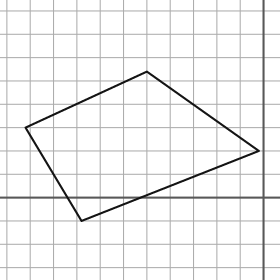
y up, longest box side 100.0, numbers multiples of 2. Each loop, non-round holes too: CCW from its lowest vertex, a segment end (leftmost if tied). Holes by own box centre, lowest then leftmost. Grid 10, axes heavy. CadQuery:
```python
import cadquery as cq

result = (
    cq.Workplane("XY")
    .moveTo(-78.0, -10.0)
    .lineTo(-2.0, 20.0)
    .lineTo(-50.0, 54.0)
    .lineTo(-102.0, 30.0)
    .close()
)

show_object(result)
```